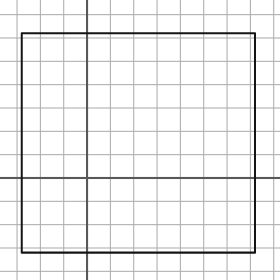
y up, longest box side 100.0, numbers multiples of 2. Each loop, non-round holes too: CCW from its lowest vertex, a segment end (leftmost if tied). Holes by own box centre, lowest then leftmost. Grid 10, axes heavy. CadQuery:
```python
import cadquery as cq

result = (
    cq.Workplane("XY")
    .moveTo(-28.0, -32.0)
    .lineTo(72.0, -32.0)
    .lineTo(72.0, 62.0)
    .lineTo(-28.0, 62.0)
    .close()
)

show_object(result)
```